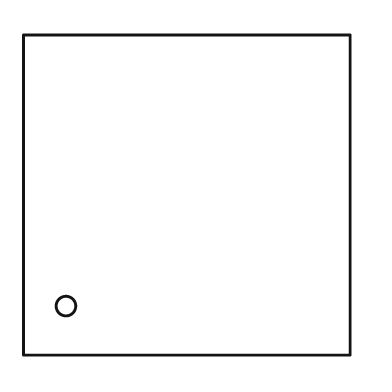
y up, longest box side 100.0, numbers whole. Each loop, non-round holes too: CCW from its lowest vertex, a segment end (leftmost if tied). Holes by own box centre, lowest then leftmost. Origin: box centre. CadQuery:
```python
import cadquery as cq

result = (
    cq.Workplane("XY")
    .moveTo(-50.0, -49.0)
    .lineTo(50.0, -49.0)
    .lineTo(50.0, 49.0)
    .lineTo(-50.0, 49.0)
    .close()
    .moveTo(-37.0, -34.0)
    .circle(3.0)
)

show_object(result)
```